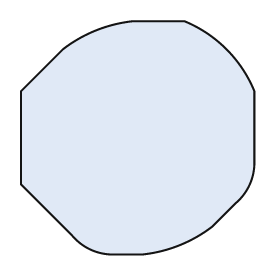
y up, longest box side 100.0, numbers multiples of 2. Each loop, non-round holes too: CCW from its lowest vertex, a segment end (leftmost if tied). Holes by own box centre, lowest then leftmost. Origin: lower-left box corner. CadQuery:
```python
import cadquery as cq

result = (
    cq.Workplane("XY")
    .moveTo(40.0, 0.0)
    .lineTo(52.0, 0.0)
    .threePointArc((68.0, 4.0), (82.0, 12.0))
    .lineTo(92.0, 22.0)
    .threePointArc((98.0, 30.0), (100.0, 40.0))
    .lineTo(100.0, 70.0)
    .threePointArc((88.0, 88.0), (70.0, 100.0))
    .lineTo(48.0, 100.0)
    .threePointArc((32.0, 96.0), (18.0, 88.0))
    .lineTo(0.0, 70.0)
    .lineTo(0.0, 30.0)
    .lineTo(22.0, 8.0)
    .threePointArc((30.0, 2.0), (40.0, 0.0))
    .close()
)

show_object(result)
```